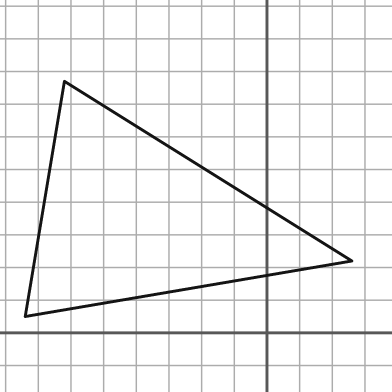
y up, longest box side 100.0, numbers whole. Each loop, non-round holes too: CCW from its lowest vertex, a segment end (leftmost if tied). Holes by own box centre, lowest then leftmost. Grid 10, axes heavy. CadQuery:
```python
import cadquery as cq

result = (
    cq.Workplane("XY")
    .moveTo(-74.0, 5.0)
    .lineTo(26.0, 22.0)
    .lineTo(-62.0, 77.0)
    .close()
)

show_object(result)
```